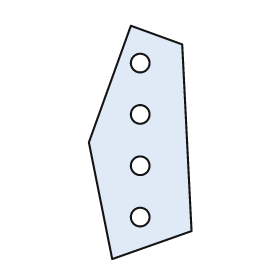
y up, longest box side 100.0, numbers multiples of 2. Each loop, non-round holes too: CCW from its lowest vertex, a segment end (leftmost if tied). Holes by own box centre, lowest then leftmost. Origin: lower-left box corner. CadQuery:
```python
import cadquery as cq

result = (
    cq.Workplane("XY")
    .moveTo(10.0, 0.0)
    .lineTo(44.0, 12.0)
    .lineTo(40.0, 92.0)
    .lineTo(18.0, 100.0)
    .lineTo(0.0, 50.0)
    .close()
    .moveTo(22.0, 18.0)
    .circle(4.0)
    .moveTo(22.0, 40.0)
    .circle(4.0)
    .moveTo(22.0, 62.0)
    .circle(4.0)
    .moveTo(22.0, 84.0)
    .circle(4.0)
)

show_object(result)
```